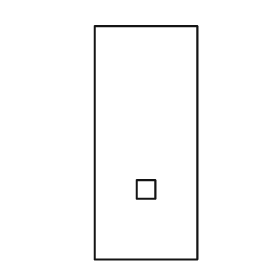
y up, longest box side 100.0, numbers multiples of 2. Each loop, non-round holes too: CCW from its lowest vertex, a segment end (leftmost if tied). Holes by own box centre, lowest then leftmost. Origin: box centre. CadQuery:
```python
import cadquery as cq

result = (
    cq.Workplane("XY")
    .moveTo(-22.0, -50.0)
    .lineTo(22.0, -50.0)
    .lineTo(22.0, 50.0)
    .lineTo(-22.0, 50.0)
    .close()
    .moveTo(-4.0, -24.0)
    .lineTo(4.0, -24.0)
    .lineTo(4.0, -16.0)
    .lineTo(-4.0, -16.0)
    .close()
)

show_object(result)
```